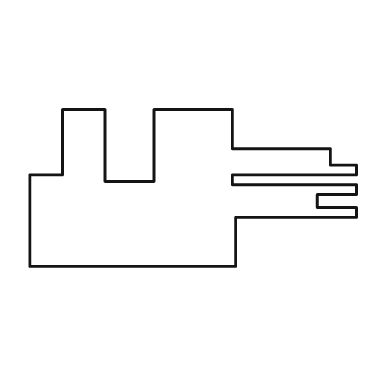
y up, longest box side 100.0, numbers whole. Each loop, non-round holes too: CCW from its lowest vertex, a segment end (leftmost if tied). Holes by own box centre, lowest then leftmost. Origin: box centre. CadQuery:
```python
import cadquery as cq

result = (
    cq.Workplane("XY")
    .moveTo(-50.0, -24.0)
    .lineTo(13.0, -24.0)
    .lineTo(13.0, -9.0)
    .lineTo(50.0, -9.0)
    .lineTo(50.0, -6.0)
    .lineTo(38.0, -6.0)
    .lineTo(38.0, -2.0)
    .lineTo(50.0, -2.0)
    .lineTo(50.0, 1.0)
    .lineTo(12.0, 1.0)
    .lineTo(12.0, 4.0)
    .lineTo(50.0, 4.0)
    .lineTo(50.0, 7.0)
    .lineTo(42.0, 7.0)
    .lineTo(42.0, 12.0)
    .lineTo(12.0, 12.0)
    .lineTo(12.0, 24.0)
    .lineTo(-12.0, 24.0)
    .lineTo(-12.0, 2.0)
    .lineTo(-27.0, 2.0)
    .lineTo(-27.0, 24.0)
    .lineTo(-40.0, 24.0)
    .lineTo(-40.0, 4.0)
    .lineTo(-50.0, 4.0)
    .close()
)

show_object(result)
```